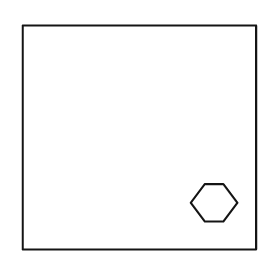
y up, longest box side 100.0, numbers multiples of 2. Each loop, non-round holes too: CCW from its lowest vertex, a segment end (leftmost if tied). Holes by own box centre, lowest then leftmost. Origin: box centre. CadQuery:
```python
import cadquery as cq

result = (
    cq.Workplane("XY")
    .moveTo(-50.0, -48.0)
    .lineTo(50.0, -48.0)
    .lineTo(50.0, 48.0)
    .lineTo(-50.0, 48.0)
    .close()
    .moveTo(28.0, -36.0)
    .lineTo(36.0, -36.0)
    .lineTo(42.0, -28.0)
    .lineTo(36.0, -20.0)
    .lineTo(28.0, -20.0)
    .lineTo(22.0, -28.0)
    .close()
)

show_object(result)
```